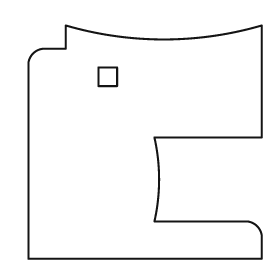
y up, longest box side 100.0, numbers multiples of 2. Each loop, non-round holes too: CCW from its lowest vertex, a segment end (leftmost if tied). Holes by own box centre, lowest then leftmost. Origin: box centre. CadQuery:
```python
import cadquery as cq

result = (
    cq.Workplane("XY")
    .moveTo(-50.0, -50.0)
    .lineTo(50.0, -50.0)
    .lineTo(50.0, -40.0)
    .threePointArc((48.0, -36.0), (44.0, -34.0))
    .lineTo(4.0, -34.0)
    .threePointArc((6.0, -16.0), (4.0, 2.0))
    .lineTo(50.0, 2.0)
    .lineTo(50.0, 50.0)
    .threePointArc((8.0, 44.0), (-34.0, 50.0))
    .lineTo(-34.0, 40.0)
    .lineTo(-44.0, 40.0)
    .threePointArc((-48.0, 38.0), (-50.0, 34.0))
    .close()
    .moveTo(-20.0, 24.0)
    .lineTo(-12.0, 24.0)
    .lineTo(-12.0, 32.0)
    .lineTo(-20.0, 32.0)
    .close()
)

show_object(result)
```